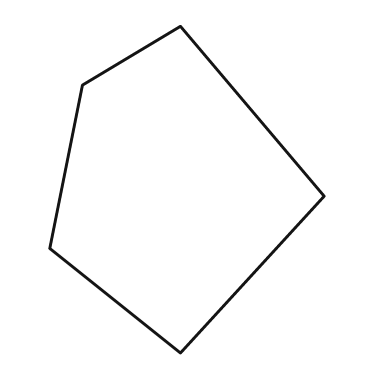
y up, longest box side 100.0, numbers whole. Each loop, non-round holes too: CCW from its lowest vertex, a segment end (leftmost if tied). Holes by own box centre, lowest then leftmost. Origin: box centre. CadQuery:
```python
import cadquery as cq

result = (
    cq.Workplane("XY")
    .moveTo(-2.0, -50.0)
    .lineTo(42.0, -2.0)
    .lineTo(-2.0, 50.0)
    .lineTo(-32.0, 32.0)
    .lineTo(-42.0, -18.0)
    .close()
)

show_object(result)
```